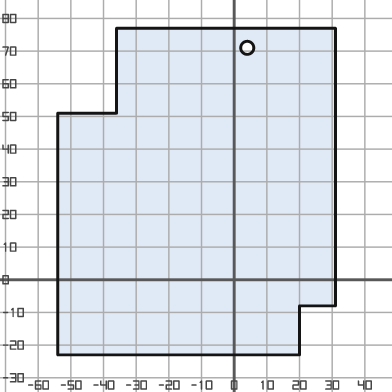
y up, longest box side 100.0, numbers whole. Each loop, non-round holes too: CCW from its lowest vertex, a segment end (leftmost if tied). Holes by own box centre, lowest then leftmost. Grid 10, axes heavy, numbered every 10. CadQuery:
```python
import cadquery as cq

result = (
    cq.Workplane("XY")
    .moveTo(-54.0, -23.0)
    .lineTo(20.0, -23.0)
    .lineTo(20.0, -8.0)
    .lineTo(31.0, -8.0)
    .lineTo(31.0, 77.0)
    .lineTo(-36.0, 77.0)
    .lineTo(-36.0, 51.0)
    .lineTo(-54.0, 51.0)
    .close()
    .moveTo(4.0, 71.0)
    .circle(2.0)
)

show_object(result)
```